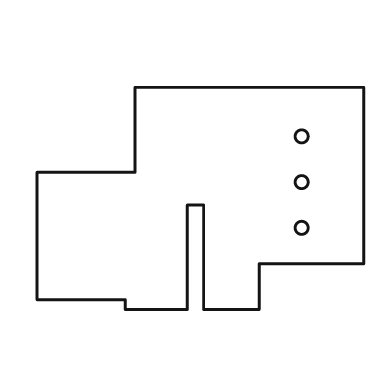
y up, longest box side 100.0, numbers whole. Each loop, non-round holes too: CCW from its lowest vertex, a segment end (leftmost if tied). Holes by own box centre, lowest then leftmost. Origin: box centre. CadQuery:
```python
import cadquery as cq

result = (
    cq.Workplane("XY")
    .moveTo(-23.0, -34.0)
    .lineTo(-4.0, -34.0)
    .lineTo(-4.0, -2.0)
    .lineTo(1.0, -2.0)
    .lineTo(1.0, -34.0)
    .lineTo(18.0, -34.0)
    .lineTo(18.0, -20.0)
    .lineTo(50.0, -20.0)
    .lineTo(50.0, 34.0)
    .lineTo(-20.0, 34.0)
    .lineTo(-20.0, 8.0)
    .lineTo(-50.0, 8.0)
    .lineTo(-50.0, -31.0)
    .lineTo(-23.0, -31.0)
    .close()
    .moveTo(31.0, -9.0)
    .circle(2.0)
    .moveTo(31.0, 5.0)
    .circle(2.0)
    .moveTo(31.0, 19.0)
    .circle(2.0)
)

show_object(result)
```